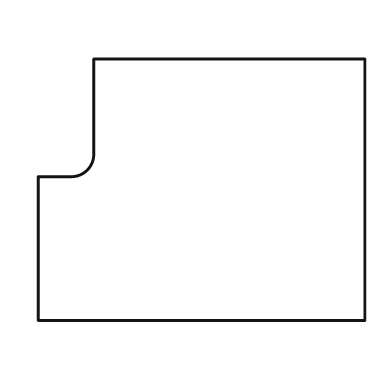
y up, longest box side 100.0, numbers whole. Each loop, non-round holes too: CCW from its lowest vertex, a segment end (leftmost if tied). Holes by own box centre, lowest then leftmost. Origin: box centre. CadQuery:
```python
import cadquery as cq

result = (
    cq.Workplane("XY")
    .moveTo(-50.0, -40.0)
    .lineTo(50.0, -40.0)
    .lineTo(50.0, 40.0)
    .lineTo(-33.0, 40.0)
    .lineTo(-33.0, 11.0)
    .threePointArc((-35.0, 6.0), (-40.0, 4.0))
    .lineTo(-50.0, 4.0)
    .close()
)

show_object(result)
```